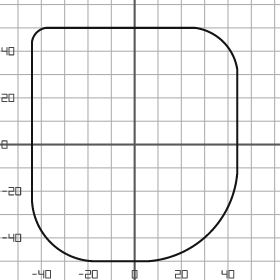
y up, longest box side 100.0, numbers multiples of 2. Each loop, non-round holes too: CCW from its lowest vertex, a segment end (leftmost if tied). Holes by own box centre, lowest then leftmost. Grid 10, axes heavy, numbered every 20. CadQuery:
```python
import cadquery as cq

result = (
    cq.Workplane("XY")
    .moveTo(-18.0, -50.0)
    .lineTo(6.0, -50.0)
    .threePointArc((32.0, -38.0), (44.0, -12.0))
    .lineTo(44.0, 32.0)
    .threePointArc((38.0, 44.0), (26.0, 50.0))
    .lineTo(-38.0, 50.0)
    .threePointArc((-42.0, 48.0), (-44.0, 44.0))
    .lineTo(-44.0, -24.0)
    .threePointArc((-36.0, -42.0), (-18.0, -50.0))
    .close()
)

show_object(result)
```